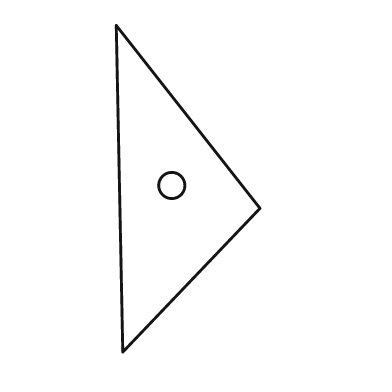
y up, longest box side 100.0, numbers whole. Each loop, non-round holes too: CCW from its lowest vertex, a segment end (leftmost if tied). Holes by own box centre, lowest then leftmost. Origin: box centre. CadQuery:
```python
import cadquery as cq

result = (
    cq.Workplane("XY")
    .moveTo(-20.0, -50.0)
    .lineTo(22.0, -6.0)
    .lineTo(-22.0, 50.0)
    .close()
    .moveTo(-5.0, 1.0)
    .circle(4.0)
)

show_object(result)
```